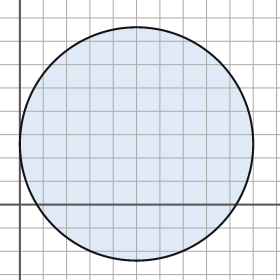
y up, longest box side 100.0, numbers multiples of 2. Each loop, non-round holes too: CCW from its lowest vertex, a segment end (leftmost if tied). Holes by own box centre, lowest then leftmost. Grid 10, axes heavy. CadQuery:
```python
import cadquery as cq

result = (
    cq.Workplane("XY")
    .moveTo(50.0, 26.0)
    .circle(50.0)
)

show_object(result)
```